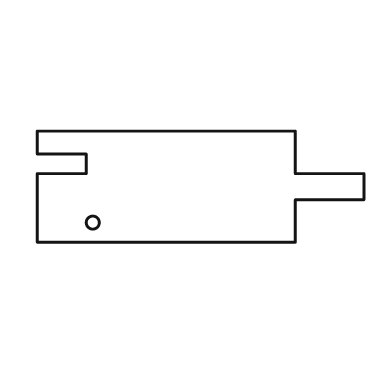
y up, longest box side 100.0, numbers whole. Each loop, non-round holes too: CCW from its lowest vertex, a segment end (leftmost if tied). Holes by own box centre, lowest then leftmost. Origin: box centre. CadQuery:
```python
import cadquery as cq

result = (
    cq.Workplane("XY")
    .moveTo(-50.0, -17.0)
    .lineTo(29.0, -17.0)
    .lineTo(29.0, -4.0)
    .lineTo(50.0, -4.0)
    .lineTo(50.0, 4.0)
    .lineTo(29.0, 4.0)
    .lineTo(29.0, 17.0)
    .lineTo(-50.0, 17.0)
    .lineTo(-50.0, 10.0)
    .lineTo(-35.0, 10.0)
    .lineTo(-35.0, 4.0)
    .lineTo(-50.0, 4.0)
    .close()
    .moveTo(-33.0, -11.0)
    .circle(2.0)
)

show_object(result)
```